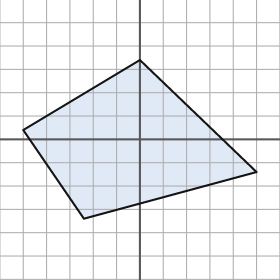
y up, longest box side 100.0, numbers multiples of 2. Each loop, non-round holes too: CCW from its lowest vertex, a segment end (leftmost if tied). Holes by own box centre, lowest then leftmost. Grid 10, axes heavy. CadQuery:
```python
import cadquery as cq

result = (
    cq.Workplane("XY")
    .moveTo(-24.0, -34.0)
    .lineTo(50.0, -14.0)
    .lineTo(0.0, 34.0)
    .lineTo(-50.0, 4.0)
    .close()
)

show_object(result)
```